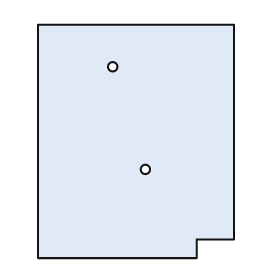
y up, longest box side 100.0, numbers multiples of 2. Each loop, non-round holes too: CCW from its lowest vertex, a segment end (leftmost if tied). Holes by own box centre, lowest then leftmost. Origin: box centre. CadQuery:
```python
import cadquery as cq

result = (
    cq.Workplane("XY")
    .moveTo(-42.0, -50.0)
    .lineTo(26.0, -50.0)
    .lineTo(26.0, -42.0)
    .lineTo(42.0, -42.0)
    .lineTo(42.0, 50.0)
    .lineTo(-42.0, 50.0)
    .close()
    .moveTo(4.0, -12.0)
    .circle(2.0)
    .moveTo(-10.0, 32.0)
    .circle(2.0)
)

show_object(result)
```